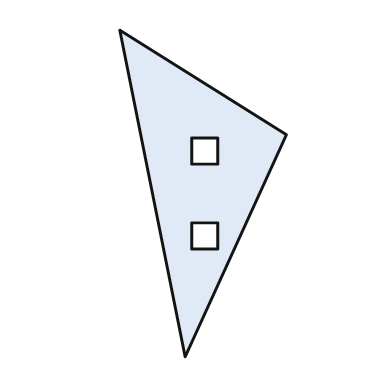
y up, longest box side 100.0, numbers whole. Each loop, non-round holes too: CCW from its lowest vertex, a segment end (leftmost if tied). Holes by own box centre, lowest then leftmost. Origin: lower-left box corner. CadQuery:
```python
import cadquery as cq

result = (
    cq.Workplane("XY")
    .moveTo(20.0, 0.0)
    .lineTo(51.0, 68.0)
    .lineTo(0.0, 100.0)
    .close()
    .moveTo(22.0, 33.0)
    .lineTo(30.0, 33.0)
    .lineTo(30.0, 41.0)
    .lineTo(22.0, 41.0)
    .close()
    .moveTo(22.0, 59.0)
    .lineTo(30.0, 59.0)
    .lineTo(30.0, 67.0)
    .lineTo(22.0, 67.0)
    .close()
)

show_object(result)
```